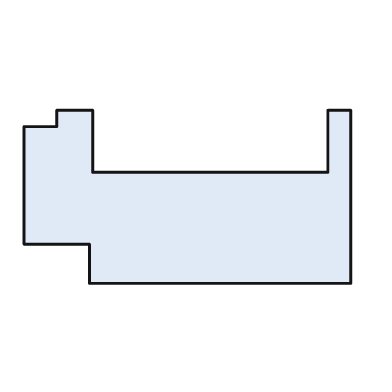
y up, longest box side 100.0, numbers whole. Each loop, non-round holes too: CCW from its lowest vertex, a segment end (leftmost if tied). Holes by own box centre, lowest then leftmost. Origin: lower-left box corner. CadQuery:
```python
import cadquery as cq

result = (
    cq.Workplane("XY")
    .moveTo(20.0, 0.0)
    .lineTo(100.0, 0.0)
    .lineTo(100.0, 53.0)
    .lineTo(93.0, 53.0)
    .lineTo(93.0, 34.0)
    .lineTo(21.0, 34.0)
    .lineTo(21.0, 53.0)
    .lineTo(10.0, 53.0)
    .lineTo(10.0, 48.0)
    .lineTo(0.0, 48.0)
    .lineTo(0.0, 12.0)
    .lineTo(20.0, 12.0)
    .close()
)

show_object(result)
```